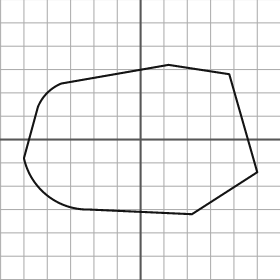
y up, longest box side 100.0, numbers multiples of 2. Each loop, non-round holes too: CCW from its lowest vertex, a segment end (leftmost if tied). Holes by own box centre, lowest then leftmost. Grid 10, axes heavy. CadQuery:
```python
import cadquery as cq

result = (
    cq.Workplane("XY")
    .moveTo(22.0, -32.0)
    .lineTo(50.0, -14.0)
    .lineTo(38.0, 28.0)
    .lineTo(12.0, 32.0)
    .lineTo(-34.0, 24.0)
    .threePointArc((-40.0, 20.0), (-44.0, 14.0))
    .lineTo(-50.0, -8.0)
    .threePointArc((-40.0, -24.0), (-22.0, -30.0))
    .close()
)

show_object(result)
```